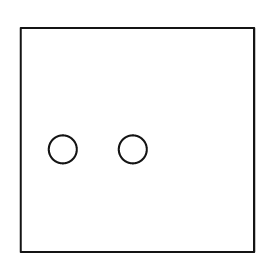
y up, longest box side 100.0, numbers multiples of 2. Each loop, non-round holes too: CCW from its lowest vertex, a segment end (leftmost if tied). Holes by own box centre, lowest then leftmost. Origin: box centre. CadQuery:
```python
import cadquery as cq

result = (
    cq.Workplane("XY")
    .moveTo(-50.0, -48.0)
    .lineTo(50.0, -48.0)
    .lineTo(50.0, 48.0)
    .lineTo(-50.0, 48.0)
    .close()
    .moveTo(-32.0, -4.0)
    .circle(6.0)
    .moveTo(-2.0, -4.0)
    .circle(6.0)
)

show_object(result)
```